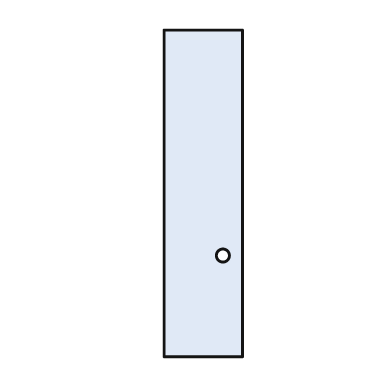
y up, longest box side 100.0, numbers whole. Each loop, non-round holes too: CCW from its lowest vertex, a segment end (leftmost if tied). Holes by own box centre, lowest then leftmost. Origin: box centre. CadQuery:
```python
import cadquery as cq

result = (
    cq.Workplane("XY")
    .moveTo(-12.0, -50.0)
    .lineTo(12.0, -50.0)
    .lineTo(12.0, 50.0)
    .lineTo(-12.0, 50.0)
    .close()
    .moveTo(6.0, -19.0)
    .circle(2.0)
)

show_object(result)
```